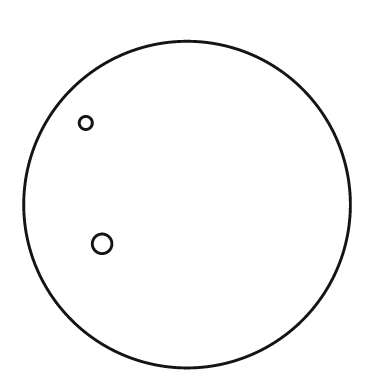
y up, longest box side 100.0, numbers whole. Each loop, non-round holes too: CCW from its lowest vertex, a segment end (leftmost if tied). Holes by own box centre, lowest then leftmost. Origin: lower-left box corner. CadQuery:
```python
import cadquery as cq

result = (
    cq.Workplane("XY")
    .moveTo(50.0, 50.0)
    .circle(50.0)
    .moveTo(24.0, 38.0)
    .circle(3.0)
    .moveTo(19.0, 75.0)
    .circle(2.0)
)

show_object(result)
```